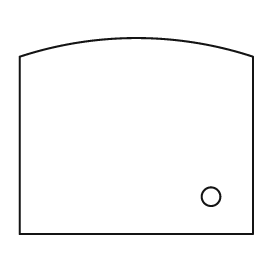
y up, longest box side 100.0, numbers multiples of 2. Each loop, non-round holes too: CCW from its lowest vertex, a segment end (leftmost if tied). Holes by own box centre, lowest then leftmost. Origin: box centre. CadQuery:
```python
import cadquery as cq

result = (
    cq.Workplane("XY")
    .moveTo(-50.0, -42.0)
    .lineTo(50.0, -42.0)
    .lineTo(50.0, 34.0)
    .threePointArc((0.0, 42.0), (-50.0, 34.0))
    .close()
    .moveTo(32.0, -26.0)
    .circle(4.0)
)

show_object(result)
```